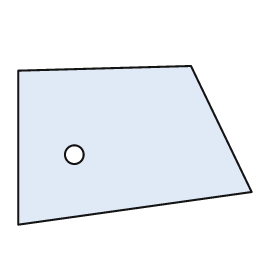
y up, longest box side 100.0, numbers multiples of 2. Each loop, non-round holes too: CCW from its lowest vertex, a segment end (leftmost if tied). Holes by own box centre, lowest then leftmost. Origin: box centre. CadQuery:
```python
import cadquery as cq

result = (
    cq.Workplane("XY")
    .moveTo(-50.0, -34.0)
    .lineTo(50.0, -20.0)
    .lineTo(24.0, 34.0)
    .lineTo(-50.0, 32.0)
    .close()
    .moveTo(-26.0, -4.0)
    .circle(4.0)
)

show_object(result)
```